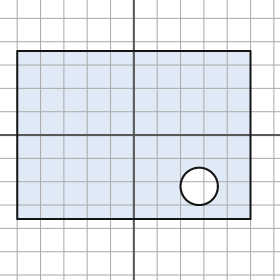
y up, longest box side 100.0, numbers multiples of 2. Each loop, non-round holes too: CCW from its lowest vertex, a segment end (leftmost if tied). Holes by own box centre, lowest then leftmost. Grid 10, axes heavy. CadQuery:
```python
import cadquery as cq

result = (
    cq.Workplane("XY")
    .moveTo(-50.0, -36.0)
    .lineTo(50.0, -36.0)
    .lineTo(50.0, 36.0)
    .lineTo(-50.0, 36.0)
    .close()
    .moveTo(28.0, -22.0)
    .circle(8.0)
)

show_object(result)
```